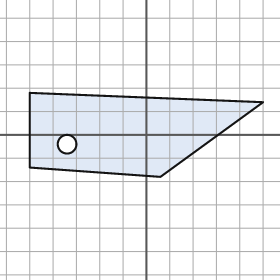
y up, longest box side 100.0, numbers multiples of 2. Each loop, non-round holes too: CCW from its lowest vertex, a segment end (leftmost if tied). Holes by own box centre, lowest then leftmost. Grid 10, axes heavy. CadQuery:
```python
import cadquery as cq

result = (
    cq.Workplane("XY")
    .moveTo(6.0, -18.0)
    .lineTo(50.0, 14.0)
    .lineTo(-50.0, 18.0)
    .lineTo(-50.0, -14.0)
    .close()
    .moveTo(-34.0, -4.0)
    .circle(4.0)
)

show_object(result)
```